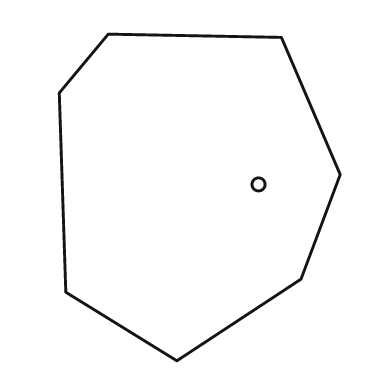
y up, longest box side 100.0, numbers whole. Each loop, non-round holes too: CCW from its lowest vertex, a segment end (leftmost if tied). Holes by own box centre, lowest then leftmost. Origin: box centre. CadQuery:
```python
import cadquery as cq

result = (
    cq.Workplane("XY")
    .moveTo(-7.0, -50.0)
    .lineTo(31.0, -25.0)
    .lineTo(43.0, 7.0)
    .lineTo(25.0, 49.0)
    .lineTo(-28.0, 50.0)
    .lineTo(-43.0, 32.0)
    .lineTo(-41.0, -29.0)
    .close()
    .moveTo(18.0, 4.0)
    .circle(2.0)
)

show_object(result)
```